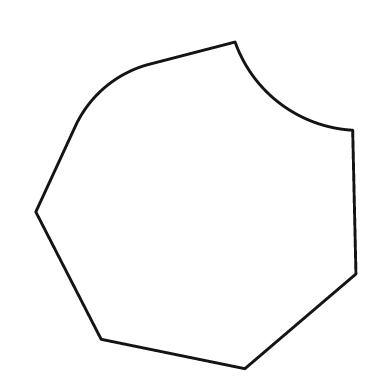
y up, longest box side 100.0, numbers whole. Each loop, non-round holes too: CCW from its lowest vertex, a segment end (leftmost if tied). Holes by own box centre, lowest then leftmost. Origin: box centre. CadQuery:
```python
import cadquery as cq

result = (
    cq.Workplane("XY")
    .moveTo(15.0, -50.0)
    .lineTo(49.0, -21.0)
    .lineTo(48.0, 23.0)
    .threePointArc((26.0, 31.0), (12.0, 50.0))
    .lineTo(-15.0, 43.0)
    .threePointArc((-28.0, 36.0), (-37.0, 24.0))
    .lineTo(-49.0, -2.0)
    .lineTo(-29.0, -41.0)
    .close()
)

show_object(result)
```